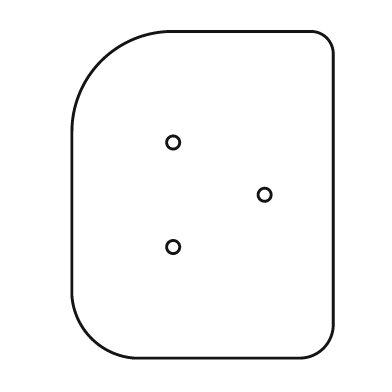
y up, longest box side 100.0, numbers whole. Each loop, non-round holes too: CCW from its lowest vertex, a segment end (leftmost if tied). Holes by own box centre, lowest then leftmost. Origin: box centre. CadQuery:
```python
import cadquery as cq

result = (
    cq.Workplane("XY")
    .moveTo(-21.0, -50.0)
    .lineTo(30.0, -50.0)
    .threePointArc((37.0, -47.0), (40.0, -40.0))
    .lineTo(40.0, 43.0)
    .threePointArc((38.0, 48.0), (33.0, 50.0))
    .lineTo(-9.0, 50.0)
    .threePointArc((-31.0, 41.0), (-40.0, 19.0))
    .lineTo(-40.0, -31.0)
    .threePointArc((-34.0, -44.0), (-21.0, -50.0))
    .close()
    .moveTo(-9.0, -16.0)
    .circle(2.0)
    .moveTo(19.0, 0.0)
    .circle(2.0)
    .moveTo(-9.0, 16.0)
    .circle(2.0)
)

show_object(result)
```